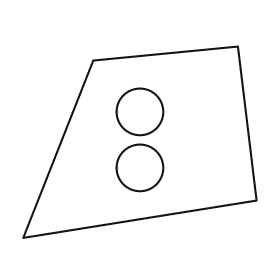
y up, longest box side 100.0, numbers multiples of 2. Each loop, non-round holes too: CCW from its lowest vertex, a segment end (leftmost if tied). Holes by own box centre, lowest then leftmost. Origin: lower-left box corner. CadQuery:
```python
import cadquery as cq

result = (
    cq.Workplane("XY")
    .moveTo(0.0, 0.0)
    .lineTo(100.0, 16.0)
    .lineTo(92.0, 82.0)
    .lineTo(30.0, 76.0)
    .close()
    .moveTo(50.0, 30.0)
    .circle(10.0)
    .moveTo(50.0, 54.0)
    .circle(10.0)
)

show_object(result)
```